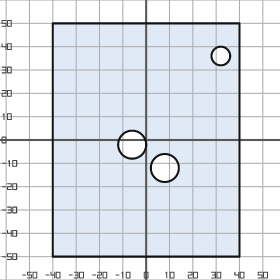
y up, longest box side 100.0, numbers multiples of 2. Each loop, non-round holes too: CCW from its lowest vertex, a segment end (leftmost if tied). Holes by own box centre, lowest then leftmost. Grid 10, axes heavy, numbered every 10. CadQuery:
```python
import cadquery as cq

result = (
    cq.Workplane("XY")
    .moveTo(-40.0, -50.0)
    .lineTo(40.0, -50.0)
    .lineTo(40.0, 50.0)
    .lineTo(-40.0, 50.0)
    .close()
    .moveTo(8.0, -12.0)
    .circle(6.0)
    .moveTo(-6.0, -2.0)
    .circle(6.0)
    .moveTo(32.0, 36.0)
    .circle(4.0)
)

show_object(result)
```